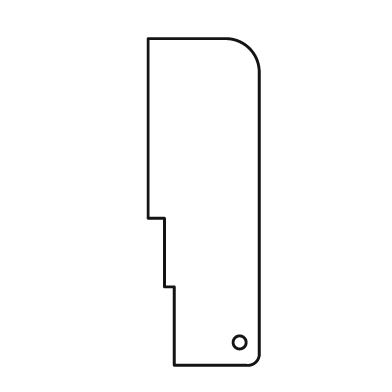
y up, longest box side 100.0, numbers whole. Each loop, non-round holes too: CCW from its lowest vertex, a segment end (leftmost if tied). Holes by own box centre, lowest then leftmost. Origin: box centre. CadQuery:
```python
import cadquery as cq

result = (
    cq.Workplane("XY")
    .moveTo(-9.0, -50.0)
    .lineTo(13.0, -50.0)
    .threePointArc((16.0, -49.0), (17.0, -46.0))
    .lineTo(17.0, 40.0)
    .threePointArc((14.0, 47.0), (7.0, 50.0))
    .lineTo(-17.0, 50.0)
    .lineTo(-17.0, -5.0)
    .lineTo(-12.0, -5.0)
    .lineTo(-12.0, -26.0)
    .lineTo(-9.0, -26.0)
    .close()
    .moveTo(11.0, -43.0)
    .circle(2.0)
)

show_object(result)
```